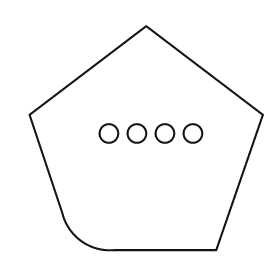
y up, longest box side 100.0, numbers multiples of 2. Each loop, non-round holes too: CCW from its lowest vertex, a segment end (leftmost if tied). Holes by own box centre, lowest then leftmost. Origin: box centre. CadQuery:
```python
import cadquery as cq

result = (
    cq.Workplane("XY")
    .moveTo(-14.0, -48.0)
    .lineTo(30.0, -48.0)
    .lineTo(50.0, 10.0)
    .lineTo(0.0, 48.0)
    .lineTo(-50.0, 10.0)
    .lineTo(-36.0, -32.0)
    .threePointArc((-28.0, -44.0), (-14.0, -48.0))
    .close()
    .moveTo(-16.0, 2.0)
    .circle(4.0)
    .moveTo(-4.0, 2.0)
    .circle(4.0)
    .moveTo(8.0, 2.0)
    .circle(4.0)
    .moveTo(20.0, 2.0)
    .circle(4.0)
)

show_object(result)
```